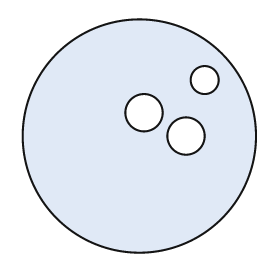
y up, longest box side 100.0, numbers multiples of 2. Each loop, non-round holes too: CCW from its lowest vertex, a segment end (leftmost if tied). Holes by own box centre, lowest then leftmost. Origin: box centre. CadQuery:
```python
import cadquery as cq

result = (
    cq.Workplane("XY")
    .moveTo(0.0, 0.0)
    .circle(50.0)
    .moveTo(20.0, 0.0)
    .circle(8.0)
    .moveTo(2.0, 10.0)
    .circle(8.0)
    .moveTo(28.0, 24.0)
    .circle(6.0)
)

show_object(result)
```